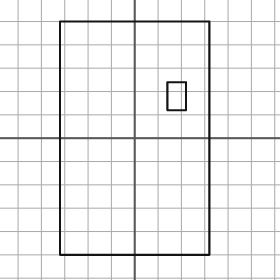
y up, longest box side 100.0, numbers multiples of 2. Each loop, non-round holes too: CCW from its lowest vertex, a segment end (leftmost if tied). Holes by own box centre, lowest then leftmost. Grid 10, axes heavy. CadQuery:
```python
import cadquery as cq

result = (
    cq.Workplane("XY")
    .moveTo(-32.0, -50.0)
    .lineTo(32.0, -50.0)
    .lineTo(32.0, 50.0)
    .lineTo(-32.0, 50.0)
    .close()
    .moveTo(14.0, 12.0)
    .lineTo(22.0, 12.0)
    .lineTo(22.0, 24.0)
    .lineTo(14.0, 24.0)
    .close()
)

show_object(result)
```